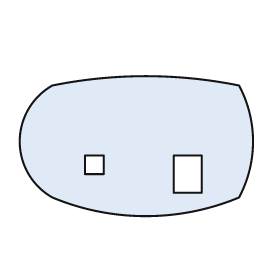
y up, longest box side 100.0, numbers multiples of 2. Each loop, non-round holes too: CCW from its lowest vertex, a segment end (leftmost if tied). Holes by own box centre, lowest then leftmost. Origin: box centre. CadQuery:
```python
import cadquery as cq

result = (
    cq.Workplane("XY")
    .moveTo(-36.0, -22.0)
    .threePointArc((4.0, -30.0), (44.0, -22.0))
    .threePointArc((50.0, 2.0), (44.0, 26.0))
    .threePointArc((4.0, 30.0), (-36.0, 26.0))
    .threePointArc((-50.0, 2.0), (-36.0, -22.0))
    .close()
    .moveTo(16.0, -20.0)
    .lineTo(28.0, -20.0)
    .lineTo(28.0, -4.0)
    .lineTo(16.0, -4.0)
    .close()
    .moveTo(-22.0, -12.0)
    .lineTo(-14.0, -12.0)
    .lineTo(-14.0, -4.0)
    .lineTo(-22.0, -4.0)
    .close()
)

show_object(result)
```